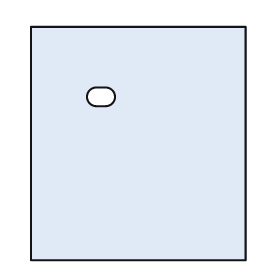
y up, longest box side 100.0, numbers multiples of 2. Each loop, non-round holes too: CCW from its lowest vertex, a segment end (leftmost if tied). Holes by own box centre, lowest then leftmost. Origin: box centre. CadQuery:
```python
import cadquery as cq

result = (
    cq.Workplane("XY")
    .moveTo(-46.0, -50.0)
    .lineTo(46.0, -50.0)
    .lineTo(46.0, 50.0)
    .lineTo(-46.0, 50.0)
    .close()
    .moveTo(-18.0, 16.0)
    .lineTo(-14.0, 16.0)
    .threePointArc((-10.0, 20.0), (-14.0, 24.0))
    .lineTo(-18.0, 24.0)
    .threePointArc((-22.0, 20.0), (-18.0, 16.0))
    .close()
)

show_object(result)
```